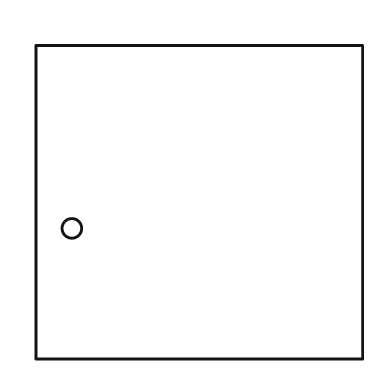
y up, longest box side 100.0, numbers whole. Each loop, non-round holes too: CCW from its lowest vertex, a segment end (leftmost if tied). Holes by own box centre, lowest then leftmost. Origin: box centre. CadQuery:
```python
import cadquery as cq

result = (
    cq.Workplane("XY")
    .moveTo(-50.0, -48.0)
    .lineTo(50.0, -48.0)
    .lineTo(50.0, 48.0)
    .lineTo(-50.0, 48.0)
    .close()
    .moveTo(-39.0, -8.0)
    .circle(3.0)
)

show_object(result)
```